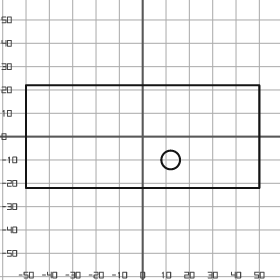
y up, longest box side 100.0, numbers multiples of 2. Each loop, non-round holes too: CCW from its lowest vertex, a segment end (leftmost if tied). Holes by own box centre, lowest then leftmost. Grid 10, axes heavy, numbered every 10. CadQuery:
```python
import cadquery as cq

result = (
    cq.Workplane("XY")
    .moveTo(-50.0, -22.0)
    .lineTo(50.0, -22.0)
    .lineTo(50.0, 22.0)
    .lineTo(-50.0, 22.0)
    .close()
    .moveTo(12.0, -10.0)
    .circle(4.0)
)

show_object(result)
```